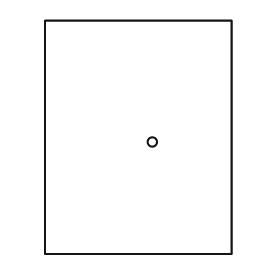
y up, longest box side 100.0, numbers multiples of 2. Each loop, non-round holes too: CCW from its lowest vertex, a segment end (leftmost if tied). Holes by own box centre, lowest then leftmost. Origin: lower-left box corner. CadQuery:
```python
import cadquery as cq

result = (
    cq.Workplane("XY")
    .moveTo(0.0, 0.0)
    .lineTo(80.0, 0.0)
    .lineTo(80.0, 100.0)
    .lineTo(0.0, 100.0)
    .close()
    .moveTo(46.0, 48.0)
    .circle(2.0)
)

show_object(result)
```